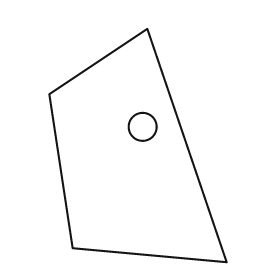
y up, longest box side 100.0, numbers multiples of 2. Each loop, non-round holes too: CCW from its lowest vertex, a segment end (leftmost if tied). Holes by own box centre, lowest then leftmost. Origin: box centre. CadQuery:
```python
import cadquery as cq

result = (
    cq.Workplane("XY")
    .moveTo(38.0, -50.0)
    .lineTo(4.0, 50.0)
    .lineTo(-38.0, 22.0)
    .lineTo(-28.0, -44.0)
    .close()
    .moveTo(2.0, 8.0)
    .circle(6.0)
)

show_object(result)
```